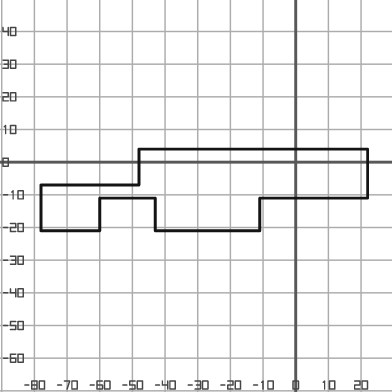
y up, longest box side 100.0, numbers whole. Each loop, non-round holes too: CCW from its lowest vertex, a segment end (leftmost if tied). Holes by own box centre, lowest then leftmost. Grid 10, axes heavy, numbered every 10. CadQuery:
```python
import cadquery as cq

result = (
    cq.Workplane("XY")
    .moveTo(-78.0, -21.0)
    .lineTo(-60.0, -21.0)
    .lineTo(-60.0, -11.0)
    .lineTo(-43.0, -11.0)
    .lineTo(-43.0, -21.0)
    .lineTo(-11.0, -21.0)
    .lineTo(-11.0, -11.0)
    .lineTo(22.0, -11.0)
    .lineTo(22.0, 4.0)
    .lineTo(-48.0, 4.0)
    .lineTo(-48.0, -7.0)
    .lineTo(-78.0, -7.0)
    .close()
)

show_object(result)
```